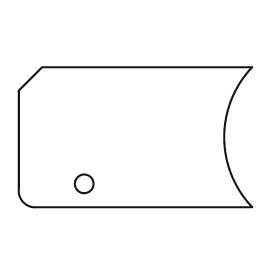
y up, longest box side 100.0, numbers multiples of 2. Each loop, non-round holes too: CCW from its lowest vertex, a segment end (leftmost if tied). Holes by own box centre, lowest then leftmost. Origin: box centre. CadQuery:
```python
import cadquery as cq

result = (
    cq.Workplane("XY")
    .moveTo(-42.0, -30.0)
    .lineTo(50.0, -30.0)
    .threePointArc((38.0, 0.0), (50.0, 30.0))
    .lineTo(-40.0, 30.0)
    .lineTo(-50.0, 20.0)
    .lineTo(-50.0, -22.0)
    .threePointArc((-48.0, -28.0), (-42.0, -30.0))
    .close()
    .moveTo(-22.0, -20.0)
    .circle(4.0)
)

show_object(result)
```